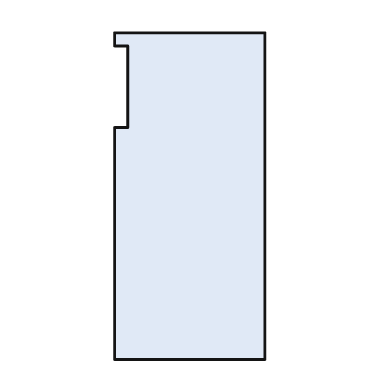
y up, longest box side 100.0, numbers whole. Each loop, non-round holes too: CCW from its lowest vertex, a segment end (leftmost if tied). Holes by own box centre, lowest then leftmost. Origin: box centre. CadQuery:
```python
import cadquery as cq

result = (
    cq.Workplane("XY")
    .moveTo(-23.0, -50.0)
    .lineTo(23.0, -50.0)
    .lineTo(23.0, 50.0)
    .lineTo(-23.0, 50.0)
    .lineTo(-23.0, 46.0)
    .lineTo(-19.0, 46.0)
    .lineTo(-19.0, 21.0)
    .lineTo(-23.0, 21.0)
    .close()
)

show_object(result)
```